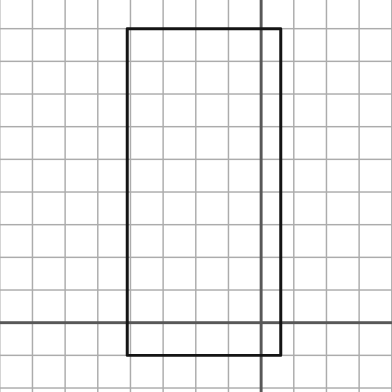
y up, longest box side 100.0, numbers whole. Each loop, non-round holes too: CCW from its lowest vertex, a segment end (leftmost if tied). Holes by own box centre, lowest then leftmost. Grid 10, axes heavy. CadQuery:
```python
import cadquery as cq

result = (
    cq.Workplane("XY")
    .moveTo(-41.0, -10.0)
    .lineTo(6.0, -10.0)
    .lineTo(6.0, 90.0)
    .lineTo(-41.0, 90.0)
    .close()
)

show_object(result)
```